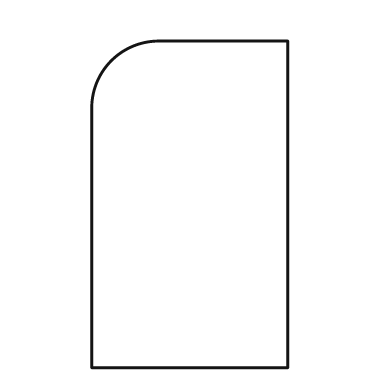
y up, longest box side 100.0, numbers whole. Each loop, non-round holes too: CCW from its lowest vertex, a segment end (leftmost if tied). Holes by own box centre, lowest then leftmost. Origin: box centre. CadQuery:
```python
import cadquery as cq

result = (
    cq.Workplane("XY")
    .moveTo(-30.0, -50.0)
    .lineTo(30.0, -50.0)
    .lineTo(30.0, 50.0)
    .lineTo(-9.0, 50.0)
    .threePointArc((-24.0, 44.0), (-30.0, 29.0))
    .close()
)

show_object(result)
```